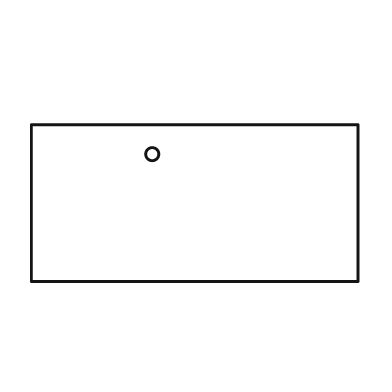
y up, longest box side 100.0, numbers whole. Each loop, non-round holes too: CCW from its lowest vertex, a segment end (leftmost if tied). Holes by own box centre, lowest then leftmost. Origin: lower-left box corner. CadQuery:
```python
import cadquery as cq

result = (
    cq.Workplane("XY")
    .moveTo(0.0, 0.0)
    .lineTo(100.0, 0.0)
    .lineTo(100.0, 48.0)
    .lineTo(0.0, 48.0)
    .close()
    .moveTo(37.0, 39.0)
    .circle(2.0)
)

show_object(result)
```